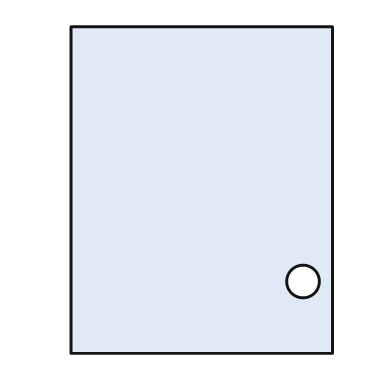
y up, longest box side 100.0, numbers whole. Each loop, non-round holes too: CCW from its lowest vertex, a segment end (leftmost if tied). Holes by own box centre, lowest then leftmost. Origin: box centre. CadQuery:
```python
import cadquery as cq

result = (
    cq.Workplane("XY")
    .moveTo(-40.0, -50.0)
    .lineTo(40.0, -50.0)
    .lineTo(40.0, 50.0)
    .lineTo(-40.0, 50.0)
    .close()
    .moveTo(31.0, -28.0)
    .circle(5.0)
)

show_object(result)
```